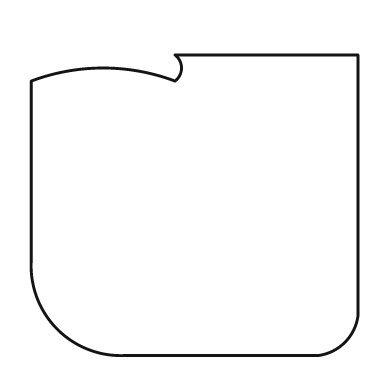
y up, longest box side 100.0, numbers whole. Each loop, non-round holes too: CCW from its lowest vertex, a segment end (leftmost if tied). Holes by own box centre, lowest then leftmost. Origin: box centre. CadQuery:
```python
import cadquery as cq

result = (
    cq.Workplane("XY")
    .moveTo(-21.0, -46.0)
    .lineTo(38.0, -46.0)
    .threePointArc((46.0, -42.0), (50.0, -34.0))
    .lineTo(50.0, 46.0)
    .lineTo(-6.0, 46.0)
    .threePointArc((-4.0, 42.0), (-6.0, 38.0))
    .threePointArc((-28.0, 42.0), (-50.0, 38.0))
    .lineTo(-50.0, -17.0)
    .threePointArc((-42.0, -38.0), (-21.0, -46.0))
    .close()
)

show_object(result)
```